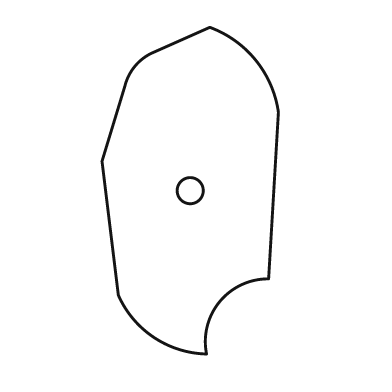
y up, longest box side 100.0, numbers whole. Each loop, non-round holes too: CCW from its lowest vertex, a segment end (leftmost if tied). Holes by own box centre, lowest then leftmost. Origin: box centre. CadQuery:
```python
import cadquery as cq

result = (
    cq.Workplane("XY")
    .moveTo(5.0, -50.0)
    .threePointArc((9.0, -34.0), (24.0, -27.0))
    .lineTo(27.0, 24.0)
    .threePointArc((20.0, 40.0), (6.0, 50.0))
    .lineTo(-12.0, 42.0)
    .threePointArc((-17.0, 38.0), (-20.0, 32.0))
    .lineTo(-27.0, 9.0)
    .lineTo(-22.0, -32.0)
    .threePointArc((-11.0, -45.0), (5.0, -50.0))
    .close()
    .moveTo(0.0, 0.0)
    .circle(4.0)
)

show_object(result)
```